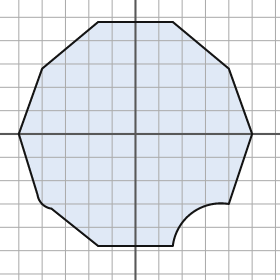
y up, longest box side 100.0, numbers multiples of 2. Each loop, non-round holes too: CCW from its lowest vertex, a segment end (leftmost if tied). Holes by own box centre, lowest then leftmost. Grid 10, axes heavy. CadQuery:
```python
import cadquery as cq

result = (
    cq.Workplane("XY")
    .moveTo(-16.0, -48.0)
    .lineTo(16.0, -48.0)
    .threePointArc((24.0, -34.0), (40.0, -30.0))
    .lineTo(50.0, 0.0)
    .lineTo(40.0, 28.0)
    .lineTo(16.0, 48.0)
    .lineTo(-16.0, 48.0)
    .lineTo(-40.0, 28.0)
    .lineTo(-50.0, 0.0)
    .lineTo(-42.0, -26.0)
    .threePointArc((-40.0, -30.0), (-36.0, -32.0))
    .close()
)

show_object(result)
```